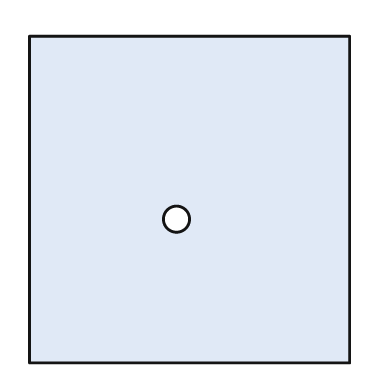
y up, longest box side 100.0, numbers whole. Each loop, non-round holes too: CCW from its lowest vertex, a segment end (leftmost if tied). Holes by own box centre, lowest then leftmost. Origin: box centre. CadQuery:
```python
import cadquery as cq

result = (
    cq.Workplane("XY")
    .moveTo(-49.0, -50.0)
    .lineTo(49.0, -50.0)
    .lineTo(49.0, 50.0)
    .lineTo(-49.0, 50.0)
    .close()
    .moveTo(-4.0, -6.0)
    .circle(4.0)
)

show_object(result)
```